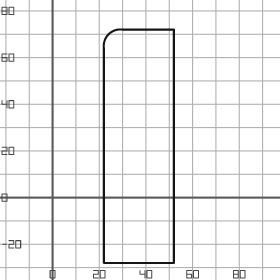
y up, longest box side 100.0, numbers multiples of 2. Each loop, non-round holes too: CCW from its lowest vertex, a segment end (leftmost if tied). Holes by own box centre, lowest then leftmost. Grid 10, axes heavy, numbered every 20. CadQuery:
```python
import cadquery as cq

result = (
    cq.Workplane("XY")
    .moveTo(22.0, -28.0)
    .lineTo(52.0, -28.0)
    .lineTo(52.0, 72.0)
    .lineTo(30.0, 72.0)
    .threePointArc((24.0, 70.0), (22.0, 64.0))
    .close()
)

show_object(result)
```